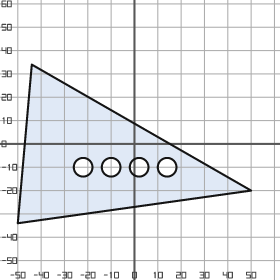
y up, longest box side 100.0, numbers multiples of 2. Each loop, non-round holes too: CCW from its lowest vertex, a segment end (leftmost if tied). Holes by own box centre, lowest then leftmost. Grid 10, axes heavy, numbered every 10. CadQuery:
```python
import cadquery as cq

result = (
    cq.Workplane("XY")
    .moveTo(-50.0, -34.0)
    .lineTo(50.0, -20.0)
    .lineTo(-44.0, 34.0)
    .close()
    .moveTo(-22.0, -10.0)
    .circle(4.0)
    .moveTo(-10.0, -10.0)
    .circle(4.0)
    .moveTo(2.0, -10.0)
    .circle(4.0)
    .moveTo(14.0, -10.0)
    .circle(4.0)
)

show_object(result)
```